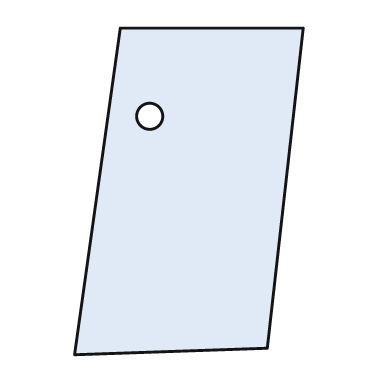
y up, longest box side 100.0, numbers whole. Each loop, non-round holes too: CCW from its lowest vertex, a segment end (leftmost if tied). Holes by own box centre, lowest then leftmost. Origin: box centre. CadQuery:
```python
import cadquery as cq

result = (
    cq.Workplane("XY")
    .moveTo(-35.0, -50.0)
    .lineTo(24.0, -48.0)
    .lineTo(35.0, 50.0)
    .lineTo(-21.0, 50.0)
    .close()
    .moveTo(-12.0, 23.0)
    .circle(4.0)
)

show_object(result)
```